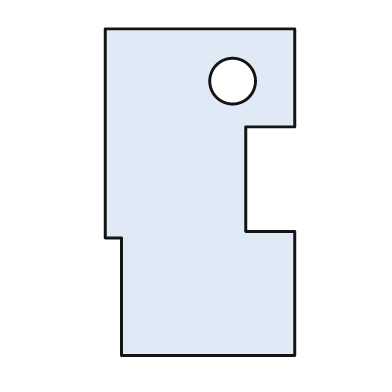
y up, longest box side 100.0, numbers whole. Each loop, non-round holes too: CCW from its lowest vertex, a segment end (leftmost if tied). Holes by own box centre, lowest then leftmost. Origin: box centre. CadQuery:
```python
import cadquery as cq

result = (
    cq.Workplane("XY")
    .moveTo(-24.0, -50.0)
    .lineTo(29.0, -50.0)
    .lineTo(29.0, -12.0)
    .lineTo(14.0, -12.0)
    .lineTo(14.0, 20.0)
    .lineTo(29.0, 20.0)
    .lineTo(29.0, 50.0)
    .lineTo(-29.0, 50.0)
    .lineTo(-29.0, -14.0)
    .lineTo(-24.0, -14.0)
    .close()
    .moveTo(10.0, 34.0)
    .circle(7.0)
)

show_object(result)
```